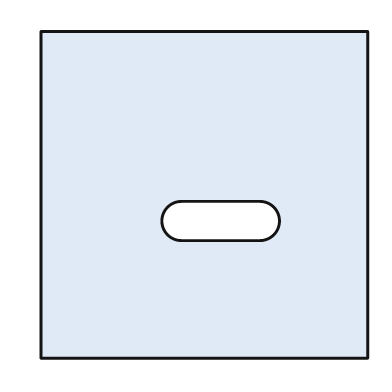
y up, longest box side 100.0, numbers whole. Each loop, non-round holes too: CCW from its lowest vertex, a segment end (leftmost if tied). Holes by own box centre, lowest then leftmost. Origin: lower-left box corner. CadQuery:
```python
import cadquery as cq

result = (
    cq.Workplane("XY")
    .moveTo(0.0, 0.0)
    .lineTo(100.0, 0.0)
    .lineTo(100.0, 100.0)
    .lineTo(0.0, 100.0)
    .close()
    .moveTo(43.0, 36.0)
    .lineTo(67.0, 36.0)
    .threePointArc((73.0, 42.0), (67.0, 48.0))
    .lineTo(43.0, 48.0)
    .threePointArc((37.0, 42.0), (43.0, 36.0))
    .close()
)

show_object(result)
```